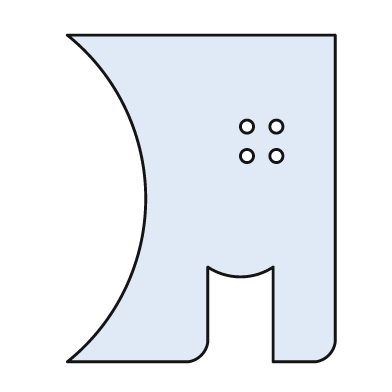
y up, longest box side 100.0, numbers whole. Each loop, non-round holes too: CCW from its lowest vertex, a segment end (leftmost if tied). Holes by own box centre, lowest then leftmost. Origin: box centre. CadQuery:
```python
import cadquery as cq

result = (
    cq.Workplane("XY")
    .moveTo(-41.0, -50.0)
    .lineTo(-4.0, -50.0)
    .threePointArc((0.0, -48.0), (2.0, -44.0))
    .lineTo(2.0, -21.0)
    .threePointArc((12.0, -24.0), (22.0, -21.0))
    .lineTo(22.0, -50.0)
    .lineTo(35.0, -50.0)
    .threePointArc((39.0, -48.0), (41.0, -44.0))
    .lineTo(41.0, 50.0)
    .lineTo(-41.0, 50.0)
    .threePointArc((-17.0, 0.0), (-41.0, -50.0))
    .close()
    .moveTo(14.0, 13.0)
    .circle(2.0)
    .moveTo(23.0, 13.0)
    .circle(2.0)
    .moveTo(14.0, 22.0)
    .circle(2.0)
    .moveTo(23.0, 22.0)
    .circle(2.0)
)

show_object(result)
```